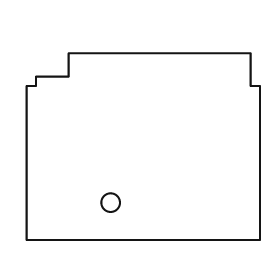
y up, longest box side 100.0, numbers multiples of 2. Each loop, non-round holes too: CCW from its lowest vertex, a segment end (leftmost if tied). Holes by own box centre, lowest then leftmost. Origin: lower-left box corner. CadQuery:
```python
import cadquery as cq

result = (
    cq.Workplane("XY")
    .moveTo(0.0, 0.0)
    .lineTo(100.0, 0.0)
    .lineTo(100.0, 66.0)
    .lineTo(96.0, 66.0)
    .lineTo(96.0, 80.0)
    .lineTo(18.0, 80.0)
    .lineTo(18.0, 70.0)
    .lineTo(4.0, 70.0)
    .lineTo(4.0, 66.0)
    .lineTo(0.0, 66.0)
    .close()
    .moveTo(36.0, 16.0)
    .circle(4.0)
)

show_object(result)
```